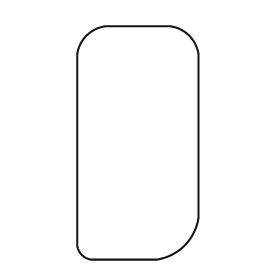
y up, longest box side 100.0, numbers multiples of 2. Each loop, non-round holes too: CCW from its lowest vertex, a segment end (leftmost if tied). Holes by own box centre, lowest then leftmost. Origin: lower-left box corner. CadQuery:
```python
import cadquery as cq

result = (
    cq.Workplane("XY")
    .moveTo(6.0, 0.0)
    .lineTo(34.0, 0.0)
    .threePointArc((46.0, 6.0), (52.0, 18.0))
    .lineTo(52.0, 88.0)
    .threePointArc((48.0, 96.0), (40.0, 100.0))
    .lineTo(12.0, 100.0)
    .threePointArc((4.0, 96.0), (0.0, 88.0))
    .lineTo(0.0, 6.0)
    .threePointArc((2.0, 2.0), (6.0, 0.0))
    .close()
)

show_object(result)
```